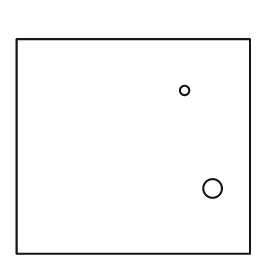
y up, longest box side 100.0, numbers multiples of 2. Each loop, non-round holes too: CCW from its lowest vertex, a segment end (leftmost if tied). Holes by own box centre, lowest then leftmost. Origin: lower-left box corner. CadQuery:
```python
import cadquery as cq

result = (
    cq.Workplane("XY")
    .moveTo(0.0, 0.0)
    .lineTo(100.0, 0.0)
    .lineTo(100.0, 92.0)
    .lineTo(0.0, 92.0)
    .close()
    .moveTo(84.0, 28.0)
    .circle(4.0)
    .moveTo(72.0, 70.0)
    .circle(2.0)
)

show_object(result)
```